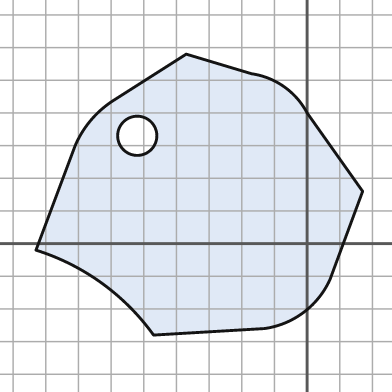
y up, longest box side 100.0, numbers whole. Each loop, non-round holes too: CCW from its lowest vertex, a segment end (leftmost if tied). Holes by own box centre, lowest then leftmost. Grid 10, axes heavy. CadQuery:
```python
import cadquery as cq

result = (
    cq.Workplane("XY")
    .moveTo(-47.0, -28.0)
    .lineTo(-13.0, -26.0)
    .threePointArc((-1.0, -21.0), (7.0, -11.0))
    .lineTo(17.0, 16.0)
    .lineTo(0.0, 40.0)
    .threePointArc((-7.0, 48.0), (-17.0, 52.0))
    .lineTo(-37.0, 58.0)
    .lineTo(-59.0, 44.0)
    .threePointArc((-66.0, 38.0), (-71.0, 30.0))
    .lineTo(-83.0, -2.0)
    .threePointArc((-63.0, -12.0), (-47.0, -28.0))
    .close()
    .moveTo(-52.0, 33.0)
    .circle(6.0)
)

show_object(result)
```